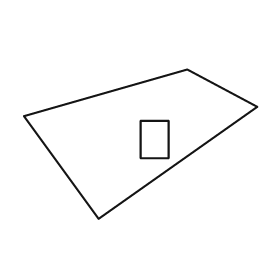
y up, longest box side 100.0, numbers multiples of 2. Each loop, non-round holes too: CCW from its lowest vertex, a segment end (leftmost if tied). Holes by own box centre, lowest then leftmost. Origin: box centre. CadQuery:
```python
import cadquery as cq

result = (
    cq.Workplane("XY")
    .moveTo(-18.0, -32.0)
    .lineTo(50.0, 16.0)
    .lineTo(20.0, 32.0)
    .lineTo(-50.0, 12.0)
    .close()
    .moveTo(0.0, -6.0)
    .lineTo(12.0, -6.0)
    .lineTo(12.0, 10.0)
    .lineTo(0.0, 10.0)
    .close()
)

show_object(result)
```